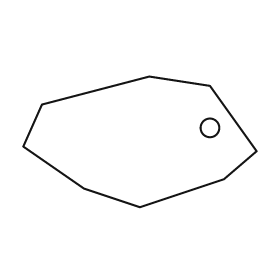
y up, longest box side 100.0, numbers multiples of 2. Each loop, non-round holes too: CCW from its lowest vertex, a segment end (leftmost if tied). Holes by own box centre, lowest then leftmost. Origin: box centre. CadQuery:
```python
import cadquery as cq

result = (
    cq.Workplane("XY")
    .moveTo(0.0, -28.0)
    .lineTo(36.0, -16.0)
    .lineTo(50.0, -4.0)
    .lineTo(30.0, 24.0)
    .lineTo(4.0, 28.0)
    .lineTo(-42.0, 16.0)
    .lineTo(-50.0, -2.0)
    .lineTo(-24.0, -20.0)
    .close()
    .moveTo(30.0, 6.0)
    .circle(4.0)
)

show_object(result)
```